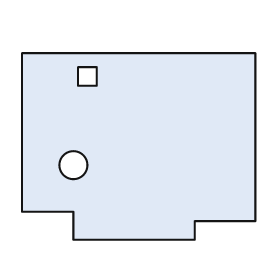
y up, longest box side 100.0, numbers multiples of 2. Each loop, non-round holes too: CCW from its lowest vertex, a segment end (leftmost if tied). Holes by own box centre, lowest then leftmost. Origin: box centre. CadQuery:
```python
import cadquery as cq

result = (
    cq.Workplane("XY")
    .moveTo(-28.0, -40.0)
    .lineTo(24.0, -40.0)
    .lineTo(24.0, -32.0)
    .lineTo(50.0, -32.0)
    .lineTo(50.0, 40.0)
    .lineTo(-50.0, 40.0)
    .lineTo(-50.0, -28.0)
    .lineTo(-28.0, -28.0)
    .close()
    .moveTo(-28.0, -8.0)
    .circle(6.0)
    .moveTo(-26.0, 26.0)
    .lineTo(-18.0, 26.0)
    .lineTo(-18.0, 34.0)
    .lineTo(-26.0, 34.0)
    .close()
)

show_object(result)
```